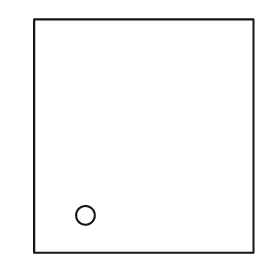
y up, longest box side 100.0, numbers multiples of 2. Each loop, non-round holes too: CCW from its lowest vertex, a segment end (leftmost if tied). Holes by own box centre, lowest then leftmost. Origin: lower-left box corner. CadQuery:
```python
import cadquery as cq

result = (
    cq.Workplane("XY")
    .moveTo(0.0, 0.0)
    .lineTo(94.0, 0.0)
    .lineTo(94.0, 100.0)
    .lineTo(0.0, 100.0)
    .close()
    .moveTo(22.0, 16.0)
    .circle(4.0)
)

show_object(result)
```